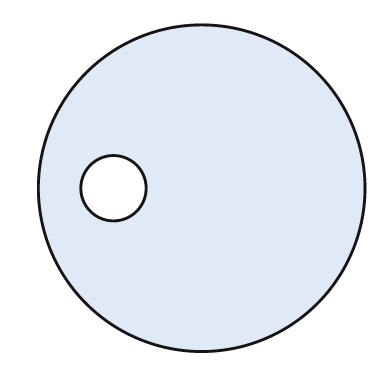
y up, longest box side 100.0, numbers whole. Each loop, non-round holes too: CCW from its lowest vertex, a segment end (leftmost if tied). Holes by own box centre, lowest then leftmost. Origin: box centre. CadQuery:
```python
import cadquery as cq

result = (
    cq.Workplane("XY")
    .moveTo(0.0, 0.0)
    .circle(50.0)
    .moveTo(-27.0, 0.0)
    .circle(10.0)
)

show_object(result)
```